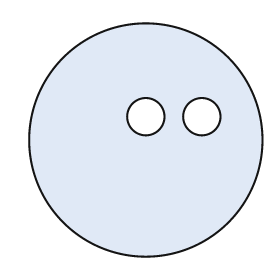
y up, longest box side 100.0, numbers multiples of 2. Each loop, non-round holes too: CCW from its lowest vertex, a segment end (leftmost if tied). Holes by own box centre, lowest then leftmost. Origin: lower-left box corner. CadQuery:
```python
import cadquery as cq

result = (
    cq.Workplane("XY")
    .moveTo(50.0, 50.0)
    .circle(50.0)
    .moveTo(50.0, 60.0)
    .circle(8.0)
    .moveTo(74.0, 60.0)
    .circle(8.0)
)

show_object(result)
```